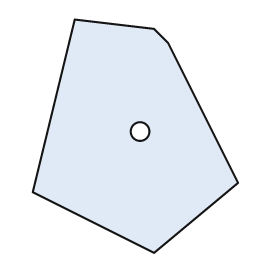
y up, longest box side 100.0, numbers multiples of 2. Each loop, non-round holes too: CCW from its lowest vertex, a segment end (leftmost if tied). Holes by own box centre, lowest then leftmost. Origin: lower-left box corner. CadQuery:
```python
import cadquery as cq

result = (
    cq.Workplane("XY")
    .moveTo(52.0, 0.0)
    .lineTo(88.0, 30.0)
    .lineTo(58.0, 90.0)
    .lineTo(52.0, 96.0)
    .lineTo(18.0, 100.0)
    .lineTo(0.0, 26.0)
    .close()
    .moveTo(46.0, 52.0)
    .circle(4.0)
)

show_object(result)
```